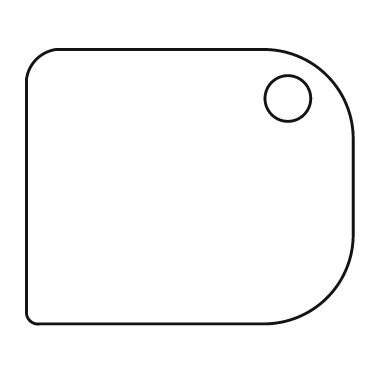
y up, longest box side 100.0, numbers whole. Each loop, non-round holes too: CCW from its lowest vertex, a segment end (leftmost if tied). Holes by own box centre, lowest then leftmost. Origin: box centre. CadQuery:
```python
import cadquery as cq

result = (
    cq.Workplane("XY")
    .moveTo(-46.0, -42.0)
    .lineTo(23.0, -42.0)
    .threePointArc((42.0, -34.0), (50.0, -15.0))
    .lineTo(50.0, 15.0)
    .threePointArc((42.0, 34.0), (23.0, 42.0))
    .lineTo(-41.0, 42.0)
    .threePointArc((-47.0, 39.0), (-50.0, 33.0))
    .lineTo(-50.0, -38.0)
    .threePointArc((-49.0, -41.0), (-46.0, -42.0))
    .close()
    .moveTo(30.0, 27.0)
    .circle(7.0)
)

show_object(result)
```